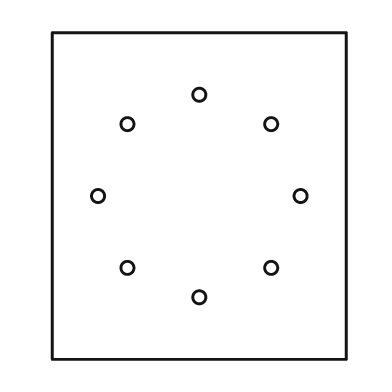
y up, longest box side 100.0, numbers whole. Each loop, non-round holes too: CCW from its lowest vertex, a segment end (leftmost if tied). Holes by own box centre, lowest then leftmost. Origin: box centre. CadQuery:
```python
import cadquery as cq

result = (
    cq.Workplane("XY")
    .moveTo(-45.0, -50.0)
    .lineTo(45.0, -50.0)
    .lineTo(45.0, 50.0)
    .lineTo(-45.0, 50.0)
    .close()
    .moveTo(0.0, -31.0)
    .circle(2.0)
    .moveTo(-22.0, -22.0)
    .circle(2.0)
    .moveTo(22.0, -22.0)
    .circle(2.0)
    .moveTo(-31.0, 0.0)
    .circle(2.0)
    .moveTo(31.0, 0.0)
    .circle(2.0)
    .moveTo(-22.0, 22.0)
    .circle(2.0)
    .moveTo(22.0, 22.0)
    .circle(2.0)
    .moveTo(0.0, 31.0)
    .circle(2.0)
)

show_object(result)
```